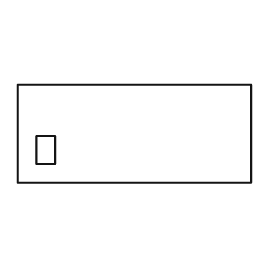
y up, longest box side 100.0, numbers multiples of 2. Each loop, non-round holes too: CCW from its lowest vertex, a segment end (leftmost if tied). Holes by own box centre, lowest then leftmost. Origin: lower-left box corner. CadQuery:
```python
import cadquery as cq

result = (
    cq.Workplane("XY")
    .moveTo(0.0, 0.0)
    .lineTo(100.0, 0.0)
    .lineTo(100.0, 42.0)
    .lineTo(0.0, 42.0)
    .close()
    .moveTo(8.0, 8.0)
    .lineTo(16.0, 8.0)
    .lineTo(16.0, 20.0)
    .lineTo(8.0, 20.0)
    .close()
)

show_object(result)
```